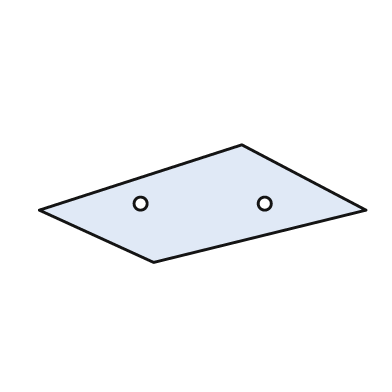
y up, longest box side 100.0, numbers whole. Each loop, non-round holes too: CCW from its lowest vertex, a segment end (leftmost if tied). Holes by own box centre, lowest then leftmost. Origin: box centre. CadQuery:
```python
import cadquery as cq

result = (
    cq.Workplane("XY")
    .moveTo(-15.0, -18.0)
    .lineTo(50.0, -2.0)
    .lineTo(12.0, 18.0)
    .lineTo(-50.0, -2.0)
    .close()
    .moveTo(-19.0, 0.0)
    .circle(2.0)
    .moveTo(19.0, 0.0)
    .circle(2.0)
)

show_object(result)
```